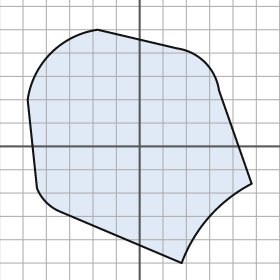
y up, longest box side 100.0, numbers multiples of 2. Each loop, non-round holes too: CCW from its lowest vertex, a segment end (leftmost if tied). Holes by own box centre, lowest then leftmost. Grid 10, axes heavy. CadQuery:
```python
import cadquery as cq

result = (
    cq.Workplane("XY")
    .moveTo(18.0, -50.0)
    .threePointArc((30.0, -30.0), (48.0, -16.0))
    .lineTo(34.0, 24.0)
    .threePointArc((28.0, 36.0), (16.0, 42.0))
    .lineTo(-18.0, 50.0)
    .threePointArc((-38.0, 40.0), (-48.0, 20.0))
    .lineTo(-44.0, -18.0)
    .threePointArc((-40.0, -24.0), (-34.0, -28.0))
    .close()
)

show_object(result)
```